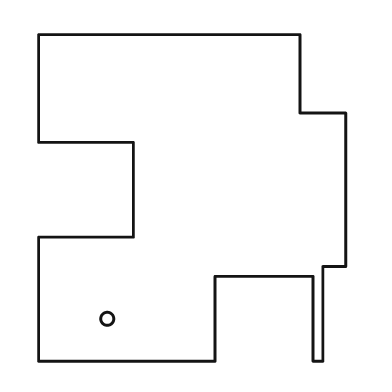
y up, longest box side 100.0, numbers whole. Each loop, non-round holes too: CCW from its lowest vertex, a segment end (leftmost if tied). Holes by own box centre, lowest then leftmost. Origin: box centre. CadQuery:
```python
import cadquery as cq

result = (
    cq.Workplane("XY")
    .moveTo(-47.0, -50.0)
    .lineTo(7.0, -50.0)
    .lineTo(7.0, -24.0)
    .lineTo(37.0, -24.0)
    .lineTo(37.0, -50.0)
    .lineTo(40.0, -50.0)
    .lineTo(40.0, -21.0)
    .lineTo(47.0, -21.0)
    .lineTo(47.0, 26.0)
    .lineTo(33.0, 26.0)
    .lineTo(33.0, 50.0)
    .lineTo(-47.0, 50.0)
    .lineTo(-47.0, 17.0)
    .lineTo(-18.0, 17.0)
    .lineTo(-18.0, -12.0)
    .lineTo(-47.0, -12.0)
    .close()
    .moveTo(-26.0, -37.0)
    .circle(2.0)
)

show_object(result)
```